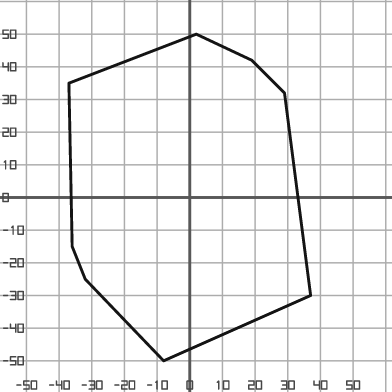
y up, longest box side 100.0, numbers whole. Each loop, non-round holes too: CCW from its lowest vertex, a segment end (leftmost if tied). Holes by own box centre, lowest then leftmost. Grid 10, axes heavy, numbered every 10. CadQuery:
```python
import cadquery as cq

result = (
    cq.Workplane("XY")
    .moveTo(-8.0, -50.0)
    .lineTo(37.0, -30.0)
    .lineTo(29.0, 32.0)
    .lineTo(19.0, 42.0)
    .lineTo(2.0, 50.0)
    .lineTo(-37.0, 35.0)
    .lineTo(-36.0, -15.0)
    .lineTo(-32.0, -25.0)
    .close()
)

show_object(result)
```